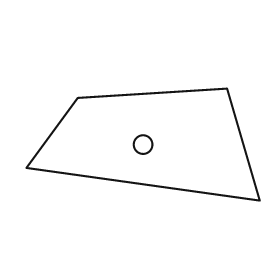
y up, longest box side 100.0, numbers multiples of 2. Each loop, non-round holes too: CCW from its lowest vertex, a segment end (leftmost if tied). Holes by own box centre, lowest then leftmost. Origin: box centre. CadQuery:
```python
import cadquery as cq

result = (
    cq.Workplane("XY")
    .moveTo(50.0, -24.0)
    .lineTo(36.0, 24.0)
    .lineTo(-28.0, 20.0)
    .lineTo(-50.0, -10.0)
    .close()
    .moveTo(0.0, 0.0)
    .circle(4.0)
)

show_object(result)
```